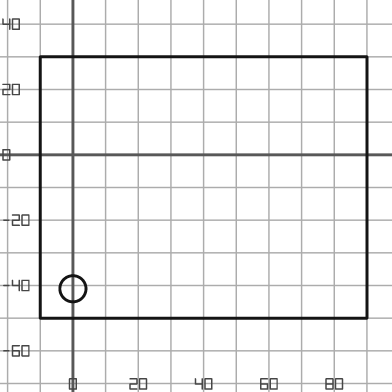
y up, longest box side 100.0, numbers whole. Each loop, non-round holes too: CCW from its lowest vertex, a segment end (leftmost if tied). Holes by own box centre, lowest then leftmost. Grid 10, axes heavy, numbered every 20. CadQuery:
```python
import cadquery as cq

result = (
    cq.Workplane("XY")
    .moveTo(-10.0, -50.0)
    .lineTo(90.0, -50.0)
    .lineTo(90.0, 30.0)
    .lineTo(-10.0, 30.0)
    .close()
    .moveTo(0.0, -41.0)
    .circle(4.0)
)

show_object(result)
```